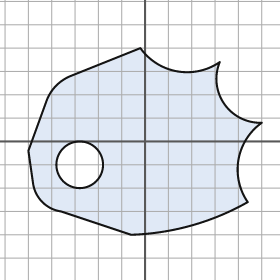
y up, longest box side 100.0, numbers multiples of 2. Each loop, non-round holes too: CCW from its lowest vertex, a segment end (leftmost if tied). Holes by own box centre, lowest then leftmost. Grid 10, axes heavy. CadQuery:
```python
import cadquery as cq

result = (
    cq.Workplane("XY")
    .moveTo(-6.0, -40.0)
    .threePointArc((20.0, -36.0), (44.0, -26.0))
    .threePointArc((40.0, -8.0), (50.0, 8.0))
    .threePointArc((34.0, 16.0), (32.0, 34.0))
    .threePointArc((14.0, 30.0), (-2.0, 40.0))
    .lineTo(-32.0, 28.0)
    .threePointArc((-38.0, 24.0), (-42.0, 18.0))
    .lineTo(-50.0, -4.0)
    .lineTo(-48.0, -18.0)
    .threePointArc((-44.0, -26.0), (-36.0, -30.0))
    .close()
    .moveTo(-28.0, -10.0)
    .circle(10.0)
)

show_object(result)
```